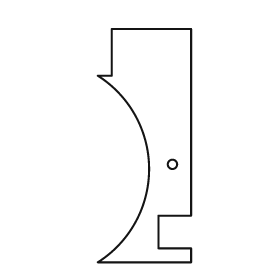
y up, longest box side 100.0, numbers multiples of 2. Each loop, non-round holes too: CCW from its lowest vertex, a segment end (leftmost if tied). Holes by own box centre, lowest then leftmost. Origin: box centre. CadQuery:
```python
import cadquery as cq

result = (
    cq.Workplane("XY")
    .moveTo(-20.0, -50.0)
    .lineTo(20.0, -50.0)
    .lineTo(20.0, -44.0)
    .lineTo(6.0, -44.0)
    .lineTo(6.0, -30.0)
    .lineTo(20.0, -30.0)
    .lineTo(20.0, 50.0)
    .lineTo(-14.0, 50.0)
    .lineTo(-14.0, 30.0)
    .lineTo(-20.0, 30.0)
    .threePointArc((2.0, -10.0), (-20.0, -50.0))
    .close()
    .moveTo(12.0, -8.0)
    .circle(2.0)
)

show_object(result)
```